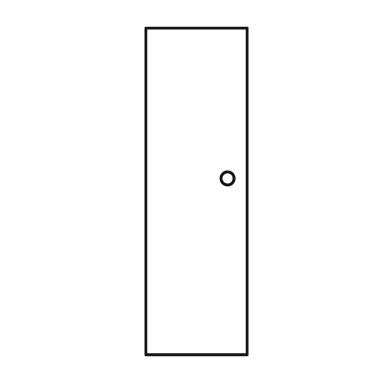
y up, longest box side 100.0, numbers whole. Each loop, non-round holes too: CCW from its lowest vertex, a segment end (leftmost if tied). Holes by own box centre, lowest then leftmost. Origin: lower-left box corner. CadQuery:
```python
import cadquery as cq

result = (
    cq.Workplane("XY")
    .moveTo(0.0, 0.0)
    .lineTo(31.0, 0.0)
    .lineTo(31.0, 100.0)
    .lineTo(0.0, 100.0)
    .close()
    .moveTo(25.0, 54.0)
    .circle(2.0)
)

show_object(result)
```